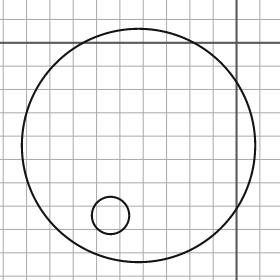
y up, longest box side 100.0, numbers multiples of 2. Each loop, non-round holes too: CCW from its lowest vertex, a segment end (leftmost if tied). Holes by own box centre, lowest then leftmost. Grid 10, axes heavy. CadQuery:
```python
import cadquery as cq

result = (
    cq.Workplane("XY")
    .moveTo(-42.0, -44.0)
    .circle(50.0)
    .moveTo(-54.0, -74.0)
    .circle(8.0)
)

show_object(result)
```